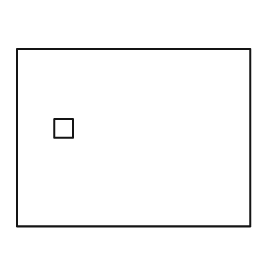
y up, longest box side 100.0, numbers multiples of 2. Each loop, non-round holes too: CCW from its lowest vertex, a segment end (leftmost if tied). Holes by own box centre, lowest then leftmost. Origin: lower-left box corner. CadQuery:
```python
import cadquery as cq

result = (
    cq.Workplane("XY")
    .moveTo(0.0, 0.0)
    .lineTo(100.0, 0.0)
    .lineTo(100.0, 76.0)
    .lineTo(0.0, 76.0)
    .close()
    .moveTo(16.0, 38.0)
    .lineTo(24.0, 38.0)
    .lineTo(24.0, 46.0)
    .lineTo(16.0, 46.0)
    .close()
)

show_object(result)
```